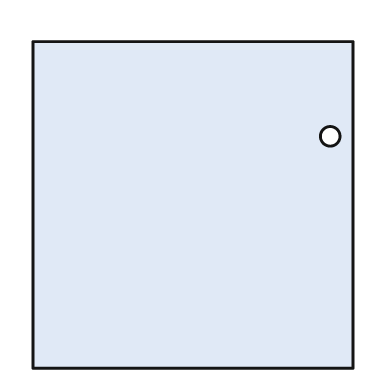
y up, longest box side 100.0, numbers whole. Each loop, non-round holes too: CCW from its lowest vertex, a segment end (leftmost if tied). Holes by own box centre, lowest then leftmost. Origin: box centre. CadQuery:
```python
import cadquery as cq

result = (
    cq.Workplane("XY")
    .moveTo(-49.0, -50.0)
    .lineTo(49.0, -50.0)
    .lineTo(49.0, 50.0)
    .lineTo(-49.0, 50.0)
    .close()
    .moveTo(42.0, 21.0)
    .circle(3.0)
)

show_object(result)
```